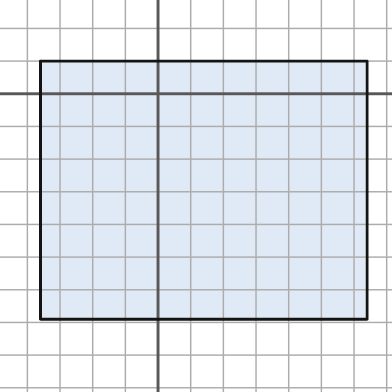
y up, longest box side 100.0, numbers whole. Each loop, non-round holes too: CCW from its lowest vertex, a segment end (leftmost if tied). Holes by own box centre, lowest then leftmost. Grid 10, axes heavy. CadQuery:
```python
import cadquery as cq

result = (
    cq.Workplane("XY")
    .moveTo(-36.0, -69.0)
    .lineTo(64.0, -69.0)
    .lineTo(64.0, 10.0)
    .lineTo(-36.0, 10.0)
    .close()
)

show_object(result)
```